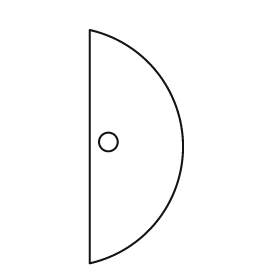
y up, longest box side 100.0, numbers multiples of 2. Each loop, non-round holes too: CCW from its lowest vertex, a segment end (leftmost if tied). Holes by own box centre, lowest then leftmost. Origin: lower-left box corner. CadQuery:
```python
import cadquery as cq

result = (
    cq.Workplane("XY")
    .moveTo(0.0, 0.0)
    .threePointArc((40.0, 50.0), (0.0, 100.0))
    .close()
    .moveTo(8.0, 52.0)
    .circle(4.0)
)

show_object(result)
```